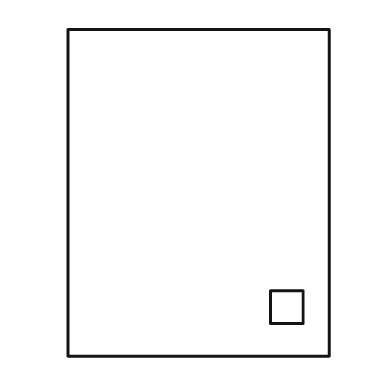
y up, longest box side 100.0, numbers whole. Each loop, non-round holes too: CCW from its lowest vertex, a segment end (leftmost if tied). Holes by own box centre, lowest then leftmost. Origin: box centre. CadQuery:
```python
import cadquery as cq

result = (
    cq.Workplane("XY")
    .moveTo(-40.0, -50.0)
    .lineTo(40.0, -50.0)
    .lineTo(40.0, 50.0)
    .lineTo(-40.0, 50.0)
    .close()
    .moveTo(22.0, -40.0)
    .lineTo(32.0, -40.0)
    .lineTo(32.0, -30.0)
    .lineTo(22.0, -30.0)
    .close()
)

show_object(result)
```